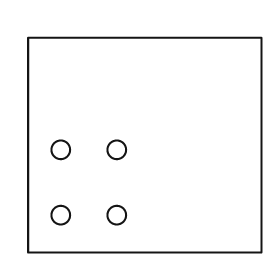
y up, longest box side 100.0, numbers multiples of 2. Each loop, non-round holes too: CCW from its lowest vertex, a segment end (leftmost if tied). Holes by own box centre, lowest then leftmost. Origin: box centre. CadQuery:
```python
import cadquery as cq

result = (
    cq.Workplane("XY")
    .moveTo(-50.0, -46.0)
    .lineTo(50.0, -46.0)
    .lineTo(50.0, 46.0)
    .lineTo(-50.0, 46.0)
    .close()
    .moveTo(-36.0, -30.0)
    .circle(4.0)
    .moveTo(-12.0, -30.0)
    .circle(4.0)
    .moveTo(-36.0, -2.0)
    .circle(4.0)
    .moveTo(-12.0, -2.0)
    .circle(4.0)
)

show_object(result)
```